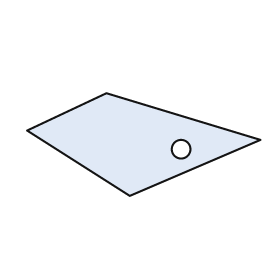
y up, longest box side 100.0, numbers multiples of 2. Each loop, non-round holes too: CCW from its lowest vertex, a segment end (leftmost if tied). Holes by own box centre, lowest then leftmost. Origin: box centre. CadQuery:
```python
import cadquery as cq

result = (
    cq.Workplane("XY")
    .moveTo(-6.0, -22.0)
    .lineTo(50.0, 2.0)
    .lineTo(-16.0, 22.0)
    .lineTo(-50.0, 6.0)
    .close()
    .moveTo(16.0, -2.0)
    .circle(4.0)
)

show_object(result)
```